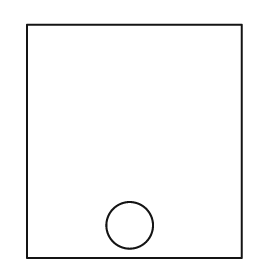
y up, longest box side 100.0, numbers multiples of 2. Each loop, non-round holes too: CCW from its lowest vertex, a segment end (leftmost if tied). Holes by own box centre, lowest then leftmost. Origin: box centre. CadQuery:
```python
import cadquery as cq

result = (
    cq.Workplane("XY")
    .moveTo(-46.0, -50.0)
    .lineTo(46.0, -50.0)
    .lineTo(46.0, 50.0)
    .lineTo(-46.0, 50.0)
    .close()
    .moveTo(-2.0, -36.0)
    .circle(10.0)
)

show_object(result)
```